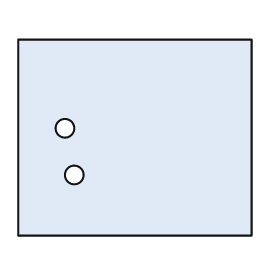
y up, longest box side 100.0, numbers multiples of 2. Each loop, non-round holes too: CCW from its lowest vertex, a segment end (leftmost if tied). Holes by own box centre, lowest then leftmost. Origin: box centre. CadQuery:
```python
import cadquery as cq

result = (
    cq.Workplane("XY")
    .moveTo(-50.0, -42.0)
    .lineTo(50.0, -42.0)
    .lineTo(50.0, 42.0)
    .lineTo(-50.0, 42.0)
    .close()
    .moveTo(-26.0, -16.0)
    .circle(4.0)
    .moveTo(-30.0, 4.0)
    .circle(4.0)
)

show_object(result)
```